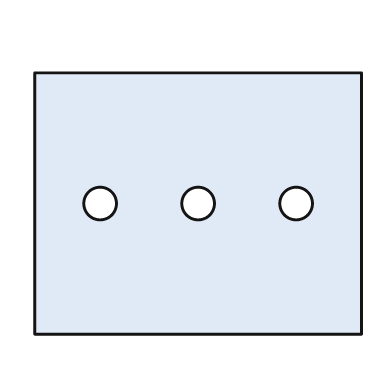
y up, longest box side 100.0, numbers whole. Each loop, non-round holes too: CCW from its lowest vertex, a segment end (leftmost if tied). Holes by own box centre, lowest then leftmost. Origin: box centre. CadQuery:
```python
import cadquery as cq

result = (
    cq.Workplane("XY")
    .moveTo(-50.0, -40.0)
    .lineTo(50.0, -40.0)
    .lineTo(50.0, 40.0)
    .lineTo(-50.0, 40.0)
    .close()
    .moveTo(-30.0, 0.0)
    .circle(5.0)
    .moveTo(0.0, 0.0)
    .circle(5.0)
    .moveTo(30.0, 0.0)
    .circle(5.0)
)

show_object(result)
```